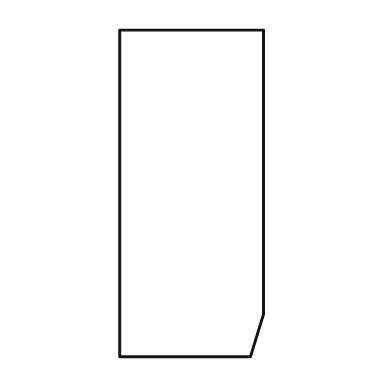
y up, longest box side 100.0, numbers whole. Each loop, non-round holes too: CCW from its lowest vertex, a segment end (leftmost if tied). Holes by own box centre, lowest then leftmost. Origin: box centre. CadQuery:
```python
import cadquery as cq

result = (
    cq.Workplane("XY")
    .moveTo(-22.0, -50.0)
    .lineTo(18.0, -50.0)
    .lineTo(22.0, -37.0)
    .lineTo(22.0, 50.0)
    .lineTo(-22.0, 50.0)
    .close()
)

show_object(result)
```